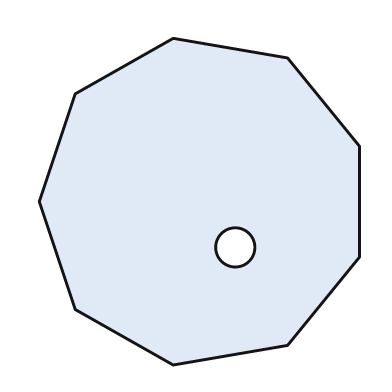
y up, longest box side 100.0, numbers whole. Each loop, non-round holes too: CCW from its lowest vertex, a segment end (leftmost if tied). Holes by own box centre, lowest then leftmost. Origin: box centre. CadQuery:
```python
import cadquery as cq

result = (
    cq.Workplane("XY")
    .moveTo(-8.0, -50.0)
    .lineTo(27.0, -44.0)
    .lineTo(49.0, -17.0)
    .lineTo(49.0, 17.0)
    .lineTo(27.0, 44.0)
    .lineTo(-8.0, 50.0)
    .lineTo(-38.0, 33.0)
    .lineTo(-49.0, 0.0)
    .lineTo(-38.0, -33.0)
    .close()
    .moveTo(11.0, -14.0)
    .circle(6.0)
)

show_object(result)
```